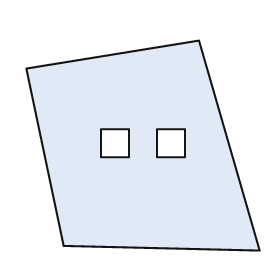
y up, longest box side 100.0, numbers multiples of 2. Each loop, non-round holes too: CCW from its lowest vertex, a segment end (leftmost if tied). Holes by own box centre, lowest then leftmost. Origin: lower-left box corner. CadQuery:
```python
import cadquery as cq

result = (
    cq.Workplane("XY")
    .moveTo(100.0, 0.0)
    .lineTo(74.0, 90.0)
    .lineTo(0.0, 78.0)
    .lineTo(16.0, 2.0)
    .close()
    .moveTo(32.0, 40.0)
    .lineTo(44.0, 40.0)
    .lineTo(44.0, 52.0)
    .lineTo(32.0, 52.0)
    .close()
    .moveTo(56.0, 40.0)
    .lineTo(68.0, 40.0)
    .lineTo(68.0, 52.0)
    .lineTo(56.0, 52.0)
    .close()
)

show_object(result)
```